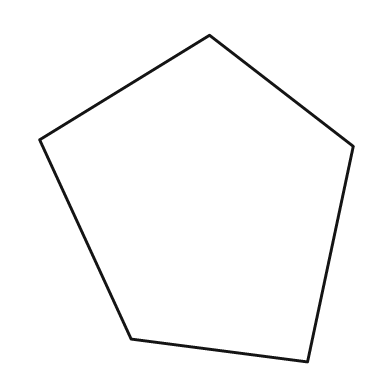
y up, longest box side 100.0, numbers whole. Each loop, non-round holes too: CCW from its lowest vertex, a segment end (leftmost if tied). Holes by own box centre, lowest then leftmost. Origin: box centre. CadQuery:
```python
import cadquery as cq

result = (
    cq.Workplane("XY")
    .moveTo(34.0, -50.0)
    .lineTo(48.0, 16.0)
    .lineTo(4.0, 50.0)
    .lineTo(-48.0, 18.0)
    .lineTo(-20.0, -43.0)
    .close()
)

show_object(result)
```